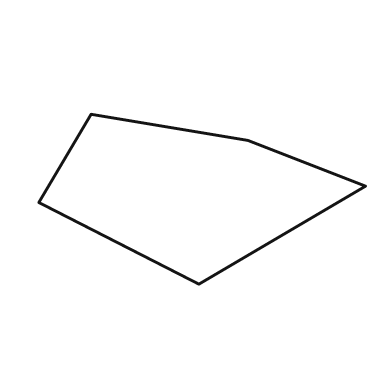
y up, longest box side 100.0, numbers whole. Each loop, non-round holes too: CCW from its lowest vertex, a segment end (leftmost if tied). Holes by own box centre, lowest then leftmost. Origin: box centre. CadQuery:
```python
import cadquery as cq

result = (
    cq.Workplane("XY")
    .moveTo(-1.0, -26.0)
    .lineTo(50.0, 4.0)
    .lineTo(14.0, 18.0)
    .lineTo(-34.0, 26.0)
    .lineTo(-50.0, -1.0)
    .close()
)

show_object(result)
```